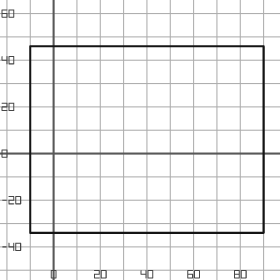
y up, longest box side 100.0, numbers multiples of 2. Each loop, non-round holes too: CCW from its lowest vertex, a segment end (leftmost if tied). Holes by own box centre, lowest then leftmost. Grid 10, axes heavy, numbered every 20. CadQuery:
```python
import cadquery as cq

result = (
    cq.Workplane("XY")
    .moveTo(-10.0, -34.0)
    .lineTo(90.0, -34.0)
    .lineTo(90.0, 46.0)
    .lineTo(-10.0, 46.0)
    .close()
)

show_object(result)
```